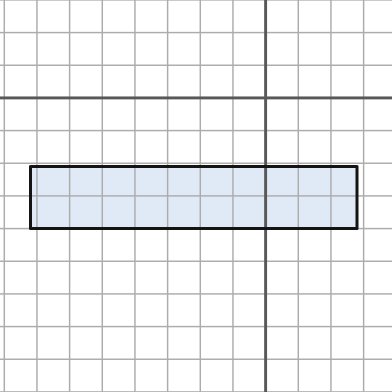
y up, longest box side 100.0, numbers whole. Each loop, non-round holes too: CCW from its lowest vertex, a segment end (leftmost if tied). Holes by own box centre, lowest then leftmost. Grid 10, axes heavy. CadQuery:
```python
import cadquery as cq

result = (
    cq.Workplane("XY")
    .moveTo(-72.0, -40.0)
    .lineTo(28.0, -40.0)
    .lineTo(28.0, -21.0)
    .lineTo(-72.0, -21.0)
    .close()
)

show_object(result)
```